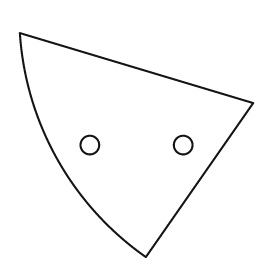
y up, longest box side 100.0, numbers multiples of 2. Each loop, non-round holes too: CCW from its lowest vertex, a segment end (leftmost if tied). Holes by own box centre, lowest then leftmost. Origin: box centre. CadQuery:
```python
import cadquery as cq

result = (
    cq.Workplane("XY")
    .moveTo(4.0, -48.0)
    .lineTo(50.0, 18.0)
    .lineTo(-50.0, 48.0)
    .threePointArc((-34.0, -6.0), (4.0, -48.0))
    .close()
    .moveTo(-20.0, 0.0)
    .circle(4.0)
    .moveTo(20.0, 0.0)
    .circle(4.0)
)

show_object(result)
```